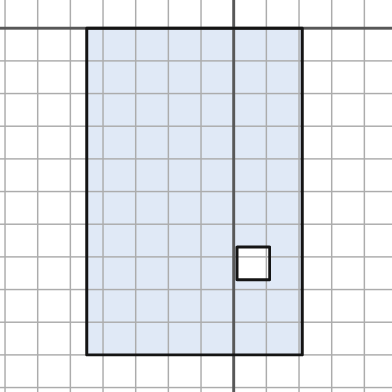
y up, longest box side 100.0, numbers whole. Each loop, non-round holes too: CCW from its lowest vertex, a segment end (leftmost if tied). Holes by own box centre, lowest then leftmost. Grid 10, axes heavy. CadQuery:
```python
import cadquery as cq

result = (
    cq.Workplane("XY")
    .moveTo(-45.0, -100.0)
    .lineTo(21.0, -100.0)
    .lineTo(21.0, 0.0)
    .lineTo(-45.0, 0.0)
    .close()
    .moveTo(1.0, -77.0)
    .lineTo(11.0, -77.0)
    .lineTo(11.0, -67.0)
    .lineTo(1.0, -67.0)
    .close()
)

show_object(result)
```